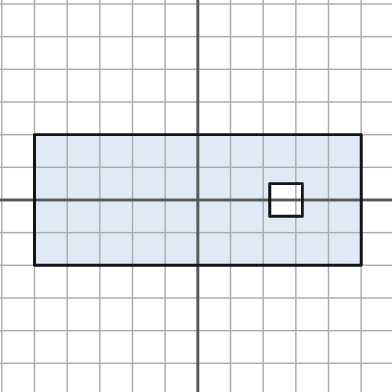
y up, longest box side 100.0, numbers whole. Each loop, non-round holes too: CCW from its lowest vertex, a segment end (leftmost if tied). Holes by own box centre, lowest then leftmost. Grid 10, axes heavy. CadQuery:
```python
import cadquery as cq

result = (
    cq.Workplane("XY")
    .moveTo(-50.0, -20.0)
    .lineTo(50.0, -20.0)
    .lineTo(50.0, 20.0)
    .lineTo(-50.0, 20.0)
    .close()
    .moveTo(22.0, -5.0)
    .lineTo(32.0, -5.0)
    .lineTo(32.0, 5.0)
    .lineTo(22.0, 5.0)
    .close()
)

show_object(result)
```